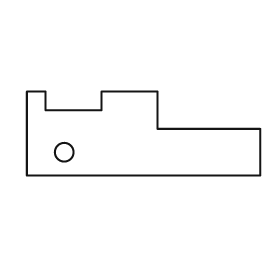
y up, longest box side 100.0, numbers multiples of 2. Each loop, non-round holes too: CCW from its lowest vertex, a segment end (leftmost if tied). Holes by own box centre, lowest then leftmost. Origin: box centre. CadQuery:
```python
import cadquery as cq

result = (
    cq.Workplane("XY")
    .moveTo(-50.0, -18.0)
    .lineTo(50.0, -18.0)
    .lineTo(50.0, 2.0)
    .lineTo(6.0, 2.0)
    .lineTo(6.0, 18.0)
    .lineTo(-18.0, 18.0)
    .lineTo(-18.0, 10.0)
    .lineTo(-42.0, 10.0)
    .lineTo(-42.0, 18.0)
    .lineTo(-50.0, 18.0)
    .close()
    .moveTo(-34.0, -8.0)
    .circle(4.0)
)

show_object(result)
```